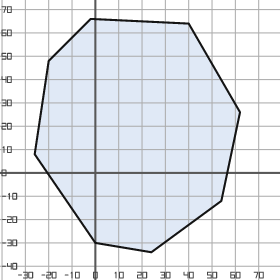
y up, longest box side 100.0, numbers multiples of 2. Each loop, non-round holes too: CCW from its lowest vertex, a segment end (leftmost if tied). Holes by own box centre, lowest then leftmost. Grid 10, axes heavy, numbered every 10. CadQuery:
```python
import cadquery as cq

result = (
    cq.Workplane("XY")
    .moveTo(24.0, -34.0)
    .lineTo(54.0, -12.0)
    .lineTo(62.0, 26.0)
    .lineTo(40.0, 64.0)
    .lineTo(-2.0, 66.0)
    .lineTo(-20.0, 48.0)
    .lineTo(-26.0, 8.0)
    .lineTo(0.0, -30.0)
    .close()
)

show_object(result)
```